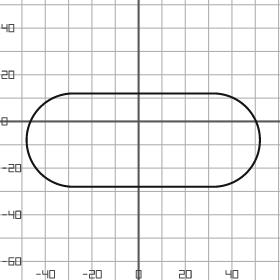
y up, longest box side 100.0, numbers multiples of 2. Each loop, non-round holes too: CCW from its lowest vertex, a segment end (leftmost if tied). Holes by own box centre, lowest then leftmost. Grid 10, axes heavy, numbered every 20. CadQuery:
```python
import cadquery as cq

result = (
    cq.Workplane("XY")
    .moveTo(-28.0, -28.0)
    .lineTo(32.0, -28.0)
    .threePointArc((52.0, -8.0), (32.0, 12.0))
    .lineTo(-28.0, 12.0)
    .threePointArc((-48.0, -8.0), (-28.0, -28.0))
    .close()
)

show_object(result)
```